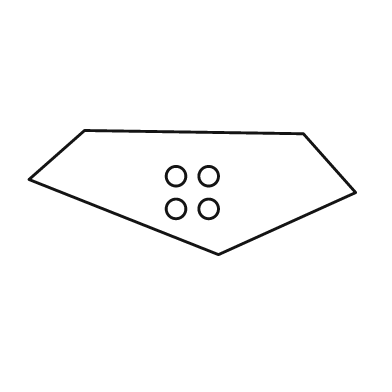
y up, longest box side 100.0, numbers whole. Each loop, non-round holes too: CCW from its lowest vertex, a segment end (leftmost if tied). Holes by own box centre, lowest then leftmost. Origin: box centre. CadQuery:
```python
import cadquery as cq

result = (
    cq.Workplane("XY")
    .moveTo(8.0, -19.0)
    .lineTo(50.0, 0.0)
    .lineTo(34.0, 18.0)
    .lineTo(-33.0, 19.0)
    .lineTo(-50.0, 4.0)
    .close()
    .moveTo(-5.0, -5.0)
    .circle(3.0)
    .moveTo(5.0, -5.0)
    .circle(3.0)
    .moveTo(-5.0, 5.0)
    .circle(3.0)
    .moveTo(5.0, 5.0)
    .circle(3.0)
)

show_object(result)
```